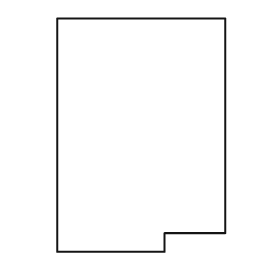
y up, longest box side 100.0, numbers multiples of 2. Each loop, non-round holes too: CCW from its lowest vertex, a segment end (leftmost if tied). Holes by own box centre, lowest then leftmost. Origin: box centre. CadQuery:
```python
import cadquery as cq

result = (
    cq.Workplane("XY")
    .moveTo(-36.0, -50.0)
    .lineTo(10.0, -50.0)
    .lineTo(10.0, -42.0)
    .lineTo(36.0, -42.0)
    .lineTo(36.0, 50.0)
    .lineTo(-36.0, 50.0)
    .close()
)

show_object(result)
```